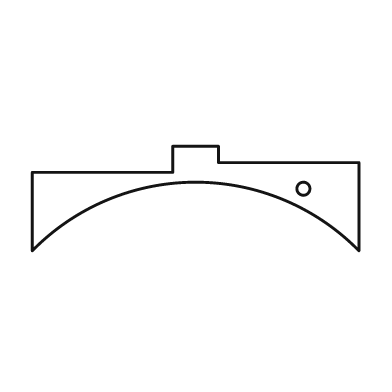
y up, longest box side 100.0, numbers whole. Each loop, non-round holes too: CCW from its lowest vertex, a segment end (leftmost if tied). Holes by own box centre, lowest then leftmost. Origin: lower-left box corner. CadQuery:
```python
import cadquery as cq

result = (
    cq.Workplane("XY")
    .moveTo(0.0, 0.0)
    .threePointArc((50.0, 21.0), (100.0, 0.0))
    .lineTo(100.0, 27.0)
    .lineTo(57.0, 27.0)
    .lineTo(57.0, 32.0)
    .lineTo(43.0, 32.0)
    .lineTo(43.0, 24.0)
    .lineTo(0.0, 24.0)
    .close()
    .moveTo(83.0, 19.0)
    .circle(2.0)
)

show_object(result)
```